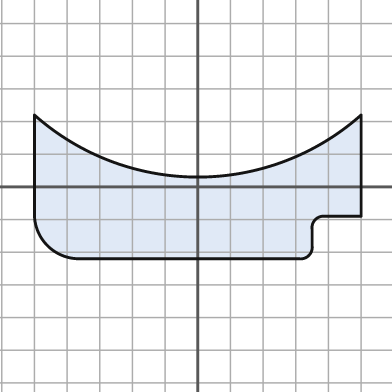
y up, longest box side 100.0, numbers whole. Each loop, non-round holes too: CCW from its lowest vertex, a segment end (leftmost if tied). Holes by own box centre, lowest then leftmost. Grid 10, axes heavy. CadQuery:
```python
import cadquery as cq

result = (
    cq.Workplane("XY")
    .moveTo(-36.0, -22.0)
    .lineTo(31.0, -22.0)
    .threePointArc((34.0, -21.0), (35.0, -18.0))
    .lineTo(35.0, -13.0)
    .threePointArc((36.0, -10.0), (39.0, -9.0))
    .lineTo(50.0, -9.0)
    .lineTo(50.0, 22.0)
    .threePointArc((0.0, 3.0), (-50.0, 22.0))
    .lineTo(-50.0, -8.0)
    .threePointArc((-46.0, -18.0), (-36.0, -22.0))
    .close()
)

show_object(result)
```